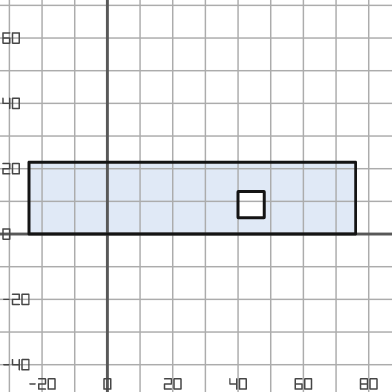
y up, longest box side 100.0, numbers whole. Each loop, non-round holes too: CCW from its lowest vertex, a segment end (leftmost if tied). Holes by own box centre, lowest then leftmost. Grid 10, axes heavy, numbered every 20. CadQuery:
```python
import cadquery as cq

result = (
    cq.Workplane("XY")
    .moveTo(-24.0, 0.0)
    .lineTo(76.0, 0.0)
    .lineTo(76.0, 22.0)
    .lineTo(-24.0, 22.0)
    .close()
    .moveTo(40.0, 5.0)
    .lineTo(48.0, 5.0)
    .lineTo(48.0, 13.0)
    .lineTo(40.0, 13.0)
    .close()
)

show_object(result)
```